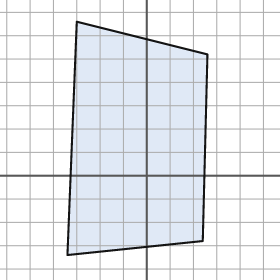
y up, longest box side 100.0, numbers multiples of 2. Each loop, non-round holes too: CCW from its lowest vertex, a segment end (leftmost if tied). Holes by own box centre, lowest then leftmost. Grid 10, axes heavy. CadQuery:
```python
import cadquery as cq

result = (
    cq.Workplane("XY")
    .moveTo(-34.0, -34.0)
    .lineTo(24.0, -28.0)
    .lineTo(26.0, 52.0)
    .lineTo(-30.0, 66.0)
    .close()
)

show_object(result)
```